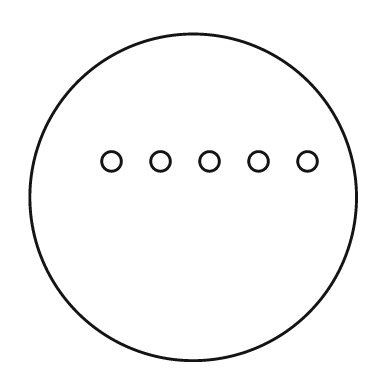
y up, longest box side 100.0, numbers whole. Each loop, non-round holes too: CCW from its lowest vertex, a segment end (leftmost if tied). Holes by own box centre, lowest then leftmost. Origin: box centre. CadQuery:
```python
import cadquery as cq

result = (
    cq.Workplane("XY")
    .moveTo(0.0, 0.0)
    .circle(50.0)
    .moveTo(-25.0, 11.0)
    .circle(3.0)
    .moveTo(-10.0, 11.0)
    .circle(3.0)
    .moveTo(5.0, 11.0)
    .circle(3.0)
    .moveTo(20.0, 11.0)
    .circle(3.0)
    .moveTo(35.0, 11.0)
    .circle(3.0)
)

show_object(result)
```